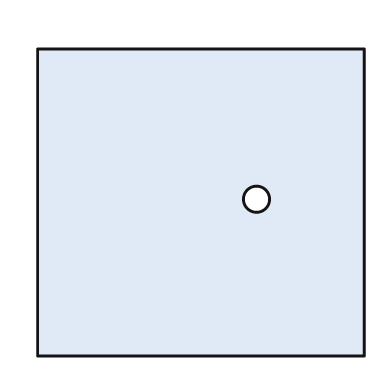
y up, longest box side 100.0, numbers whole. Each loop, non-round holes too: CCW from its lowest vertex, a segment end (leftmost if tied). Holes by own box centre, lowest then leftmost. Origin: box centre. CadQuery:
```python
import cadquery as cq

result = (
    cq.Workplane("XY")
    .moveTo(-50.0, -47.0)
    .lineTo(50.0, -47.0)
    .lineTo(50.0, 47.0)
    .lineTo(-50.0, 47.0)
    .close()
    .moveTo(17.0, 1.0)
    .circle(4.0)
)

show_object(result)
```